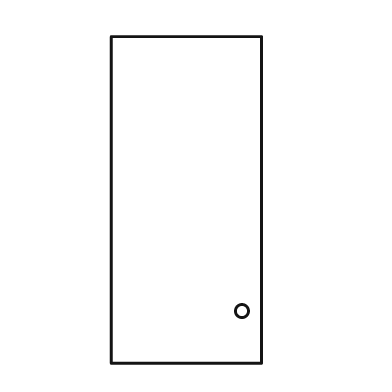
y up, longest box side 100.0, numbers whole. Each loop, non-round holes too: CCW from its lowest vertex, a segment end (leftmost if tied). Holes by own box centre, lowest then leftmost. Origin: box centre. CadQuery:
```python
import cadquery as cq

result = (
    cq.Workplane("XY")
    .moveTo(-23.0, -50.0)
    .lineTo(23.0, -50.0)
    .lineTo(23.0, 50.0)
    .lineTo(-23.0, 50.0)
    .close()
    .moveTo(17.0, -34.0)
    .circle(2.0)
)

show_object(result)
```